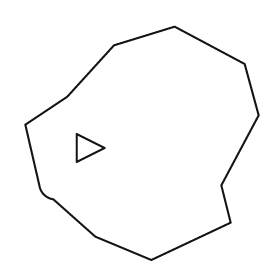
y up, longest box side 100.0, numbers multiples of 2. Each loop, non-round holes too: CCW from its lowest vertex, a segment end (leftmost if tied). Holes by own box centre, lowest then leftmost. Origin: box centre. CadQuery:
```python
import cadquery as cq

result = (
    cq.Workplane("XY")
    .moveTo(4.0, -50.0)
    .lineTo(38.0, -34.0)
    .lineTo(34.0, -18.0)
    .lineTo(50.0, 12.0)
    .lineTo(44.0, 34.0)
    .lineTo(14.0, 50.0)
    .lineTo(-12.0, 42.0)
    .lineTo(-32.0, 20.0)
    .lineTo(-50.0, 8.0)
    .lineTo(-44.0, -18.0)
    .threePointArc((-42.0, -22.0), (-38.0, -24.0))
    .lineTo(-20.0, -40.0)
    .close()
    .moveTo(-28.0, -8.0)
    .lineTo(-16.0, -2.0)
    .lineTo(-28.0, 4.0)
    .close()
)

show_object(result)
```